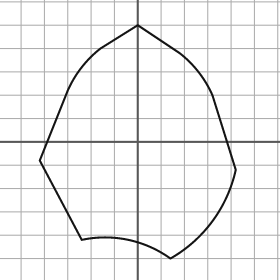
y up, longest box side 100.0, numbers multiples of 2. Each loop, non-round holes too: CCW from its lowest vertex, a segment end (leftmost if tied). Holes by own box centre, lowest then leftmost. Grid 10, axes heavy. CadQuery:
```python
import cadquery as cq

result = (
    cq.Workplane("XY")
    .moveTo(14.0, -50.0)
    .threePointArc((32.0, -34.0), (42.0, -12.0))
    .lineTo(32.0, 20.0)
    .threePointArc((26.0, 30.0), (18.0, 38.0))
    .lineTo(0.0, 50.0)
    .lineTo(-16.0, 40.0)
    .threePointArc((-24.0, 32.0), (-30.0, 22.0))
    .lineTo(-42.0, -8.0)
    .lineTo(-24.0, -42.0)
    .threePointArc((-4.0, -42.0), (14.0, -50.0))
    .close()
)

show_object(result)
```